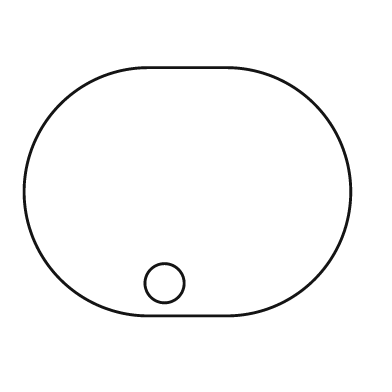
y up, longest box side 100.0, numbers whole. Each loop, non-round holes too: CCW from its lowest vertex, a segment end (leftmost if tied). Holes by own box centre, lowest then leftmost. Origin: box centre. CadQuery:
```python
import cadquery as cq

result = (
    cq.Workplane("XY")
    .moveTo(-12.0, -38.0)
    .lineTo(12.0, -38.0)
    .threePointArc((50.0, 0.0), (12.0, 38.0))
    .lineTo(-12.0, 38.0)
    .threePointArc((-50.0, 0.0), (-12.0, -38.0))
    .close()
    .moveTo(-7.0, -28.0)
    .circle(6.0)
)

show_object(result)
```